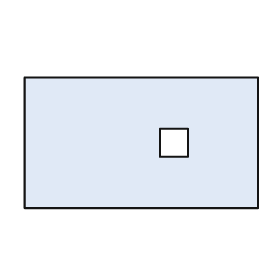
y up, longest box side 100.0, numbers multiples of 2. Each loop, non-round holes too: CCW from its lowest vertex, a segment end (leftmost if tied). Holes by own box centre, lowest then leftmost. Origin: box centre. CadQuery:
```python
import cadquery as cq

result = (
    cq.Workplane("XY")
    .moveTo(-50.0, -28.0)
    .lineTo(50.0, -28.0)
    .lineTo(50.0, 28.0)
    .lineTo(-50.0, 28.0)
    .close()
    .moveTo(8.0, -6.0)
    .lineTo(20.0, -6.0)
    .lineTo(20.0, 6.0)
    .lineTo(8.0, 6.0)
    .close()
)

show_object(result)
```